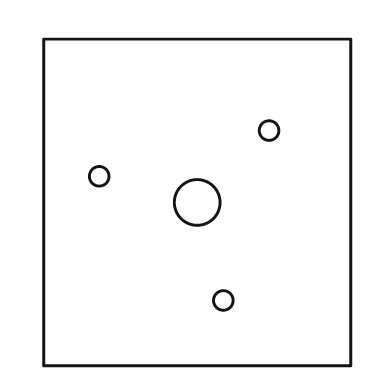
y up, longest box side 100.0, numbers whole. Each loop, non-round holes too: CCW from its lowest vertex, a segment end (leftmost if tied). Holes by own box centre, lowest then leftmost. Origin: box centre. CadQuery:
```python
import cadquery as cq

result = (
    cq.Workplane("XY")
    .moveTo(-47.0, -50.0)
    .lineTo(47.0, -50.0)
    .lineTo(47.0, 50.0)
    .lineTo(-47.0, 50.0)
    .close()
    .moveTo(8.0, -30.0)
    .circle(3.0)
    .moveTo(0.0, 0.0)
    .circle(7.0)
    .moveTo(-30.0, 8.0)
    .circle(3.0)
    .moveTo(22.0, 22.0)
    .circle(3.0)
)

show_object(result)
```